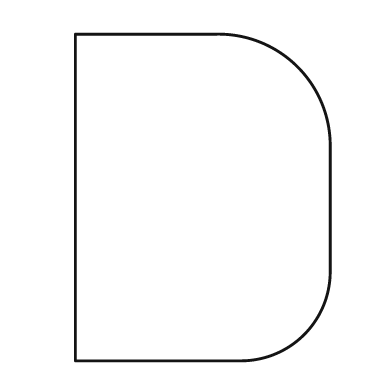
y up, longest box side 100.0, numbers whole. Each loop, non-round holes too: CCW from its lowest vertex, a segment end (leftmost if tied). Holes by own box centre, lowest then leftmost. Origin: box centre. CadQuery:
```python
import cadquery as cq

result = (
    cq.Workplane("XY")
    .moveTo(-39.0, -50.0)
    .lineTo(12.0, -50.0)
    .threePointArc((31.0, -42.0), (39.0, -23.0))
    .lineTo(39.0, 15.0)
    .threePointArc((29.0, 40.0), (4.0, 50.0))
    .lineTo(-39.0, 50.0)
    .close()
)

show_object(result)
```